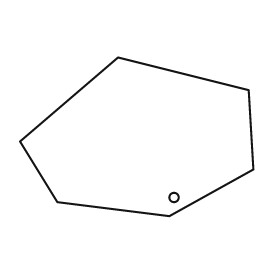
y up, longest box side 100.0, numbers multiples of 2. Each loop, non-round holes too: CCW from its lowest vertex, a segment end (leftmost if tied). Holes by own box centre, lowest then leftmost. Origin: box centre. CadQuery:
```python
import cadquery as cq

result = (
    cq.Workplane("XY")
    .moveTo(14.0, -34.0)
    .lineTo(50.0, -14.0)
    .lineTo(48.0, 20.0)
    .lineTo(-8.0, 34.0)
    .lineTo(-50.0, -2.0)
    .lineTo(-34.0, -28.0)
    .close()
    .moveTo(16.0, -26.0)
    .circle(2.0)
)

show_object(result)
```